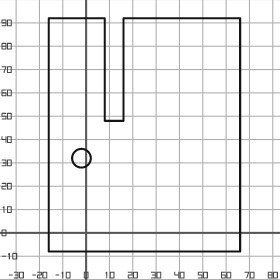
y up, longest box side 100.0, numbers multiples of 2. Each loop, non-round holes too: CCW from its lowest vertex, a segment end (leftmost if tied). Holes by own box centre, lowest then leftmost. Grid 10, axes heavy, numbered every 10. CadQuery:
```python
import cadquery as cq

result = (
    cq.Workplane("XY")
    .moveTo(-16.0, -8.0)
    .lineTo(66.0, -8.0)
    .lineTo(66.0, 92.0)
    .lineTo(16.0, 92.0)
    .lineTo(16.0, 48.0)
    .lineTo(8.0, 48.0)
    .lineTo(8.0, 92.0)
    .lineTo(-16.0, 92.0)
    .close()
    .moveTo(-2.0, 32.0)
    .circle(4.0)
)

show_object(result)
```